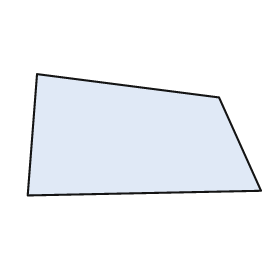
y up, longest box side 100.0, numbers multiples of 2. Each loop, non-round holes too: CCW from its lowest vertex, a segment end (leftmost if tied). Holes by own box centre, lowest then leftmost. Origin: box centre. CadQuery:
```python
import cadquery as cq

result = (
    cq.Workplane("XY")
    .moveTo(-50.0, -26.0)
    .lineTo(50.0, -24.0)
    .lineTo(32.0, 16.0)
    .lineTo(-46.0, 26.0)
    .close()
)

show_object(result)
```